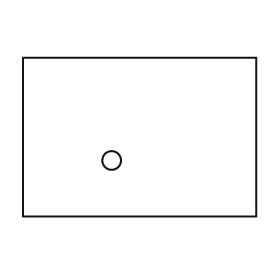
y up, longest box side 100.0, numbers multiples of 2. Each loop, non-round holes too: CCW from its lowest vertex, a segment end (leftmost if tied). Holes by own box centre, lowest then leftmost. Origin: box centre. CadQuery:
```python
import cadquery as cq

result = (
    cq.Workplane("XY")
    .moveTo(-50.0, -34.0)
    .lineTo(50.0, -34.0)
    .lineTo(50.0, 34.0)
    .lineTo(-50.0, 34.0)
    .close()
    .moveTo(-12.0, -10.0)
    .circle(4.0)
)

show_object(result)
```